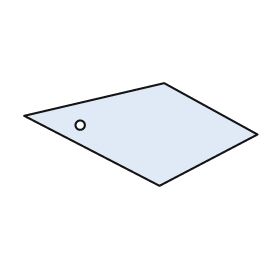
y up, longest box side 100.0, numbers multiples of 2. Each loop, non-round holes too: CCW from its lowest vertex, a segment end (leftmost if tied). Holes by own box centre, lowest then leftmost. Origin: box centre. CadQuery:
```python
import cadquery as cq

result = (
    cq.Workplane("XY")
    .moveTo(8.0, -22.0)
    .lineTo(50.0, 0.0)
    .lineTo(10.0, 22.0)
    .lineTo(-50.0, 8.0)
    .close()
    .moveTo(-26.0, 4.0)
    .circle(2.0)
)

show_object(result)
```